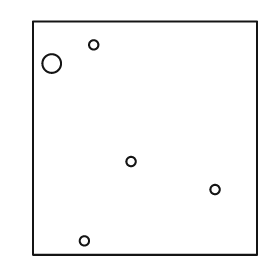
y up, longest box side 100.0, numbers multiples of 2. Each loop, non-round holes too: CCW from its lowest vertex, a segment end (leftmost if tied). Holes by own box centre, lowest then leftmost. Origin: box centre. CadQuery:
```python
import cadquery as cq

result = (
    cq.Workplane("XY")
    .moveTo(-48.0, -50.0)
    .lineTo(48.0, -50.0)
    .lineTo(48.0, 50.0)
    .lineTo(-48.0, 50.0)
    .close()
    .moveTo(-26.0, -44.0)
    .circle(2.0)
    .moveTo(30.0, -22.0)
    .circle(2.0)
    .moveTo(-6.0, -10.0)
    .circle(2.0)
    .moveTo(-40.0, 32.0)
    .circle(4.0)
    .moveTo(-22.0, 40.0)
    .circle(2.0)
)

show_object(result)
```